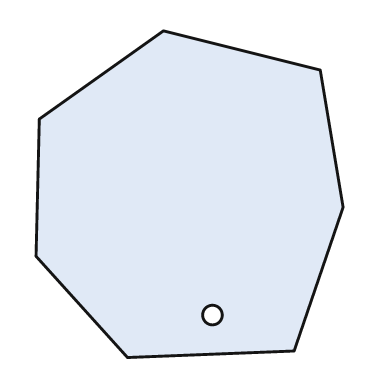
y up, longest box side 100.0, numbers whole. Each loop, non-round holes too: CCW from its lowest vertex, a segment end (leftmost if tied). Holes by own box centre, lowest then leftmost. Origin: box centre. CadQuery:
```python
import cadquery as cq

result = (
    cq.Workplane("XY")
    .moveTo(-19.0, -50.0)
    .lineTo(32.0, -48.0)
    .lineTo(47.0, -4.0)
    .lineTo(40.0, 38.0)
    .lineTo(-8.0, 50.0)
    .lineTo(-46.0, 23.0)
    .lineTo(-47.0, -19.0)
    .close()
    .moveTo(7.0, -37.0)
    .circle(3.0)
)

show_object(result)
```